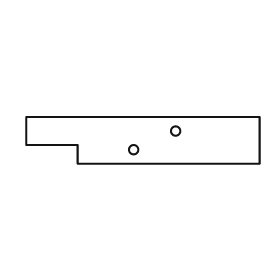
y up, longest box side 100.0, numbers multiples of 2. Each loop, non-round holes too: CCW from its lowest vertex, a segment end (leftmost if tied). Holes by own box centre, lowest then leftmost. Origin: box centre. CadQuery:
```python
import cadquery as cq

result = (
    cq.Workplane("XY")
    .moveTo(-28.0, -10.0)
    .lineTo(50.0, -10.0)
    .lineTo(50.0, 10.0)
    .lineTo(-50.0, 10.0)
    .lineTo(-50.0, -2.0)
    .lineTo(-28.0, -2.0)
    .close()
    .moveTo(-4.0, -4.0)
    .circle(2.0)
    .moveTo(14.0, 4.0)
    .circle(2.0)
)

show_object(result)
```